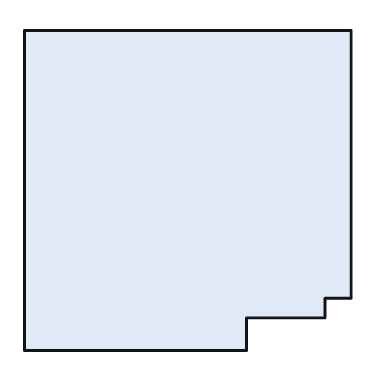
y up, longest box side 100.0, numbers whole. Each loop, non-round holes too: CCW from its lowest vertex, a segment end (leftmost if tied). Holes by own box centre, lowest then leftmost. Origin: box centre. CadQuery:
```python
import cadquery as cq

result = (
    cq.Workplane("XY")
    .moveTo(-50.0, -49.0)
    .lineTo(18.0, -49.0)
    .lineTo(18.0, -39.0)
    .lineTo(42.0, -39.0)
    .lineTo(42.0, -33.0)
    .lineTo(50.0, -33.0)
    .lineTo(50.0, 49.0)
    .lineTo(-50.0, 49.0)
    .close()
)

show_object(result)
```